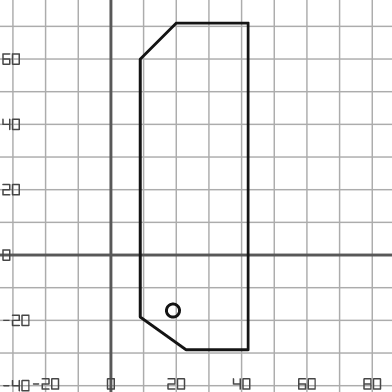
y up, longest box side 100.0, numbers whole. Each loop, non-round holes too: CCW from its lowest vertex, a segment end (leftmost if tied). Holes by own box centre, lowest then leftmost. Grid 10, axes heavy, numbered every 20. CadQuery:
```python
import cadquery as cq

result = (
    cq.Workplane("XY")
    .moveTo(23.0, -29.0)
    .lineTo(42.0, -29.0)
    .lineTo(42.0, 71.0)
    .lineTo(20.0, 71.0)
    .lineTo(9.0, 60.0)
    .lineTo(9.0, -19.0)
    .close()
    .moveTo(19.0, -17.0)
    .circle(2.0)
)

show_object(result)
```